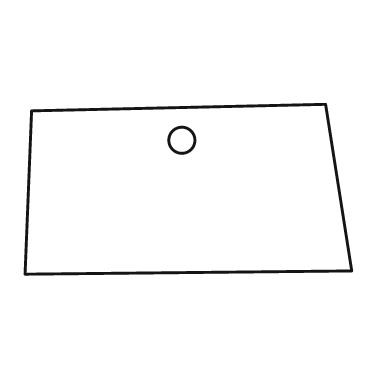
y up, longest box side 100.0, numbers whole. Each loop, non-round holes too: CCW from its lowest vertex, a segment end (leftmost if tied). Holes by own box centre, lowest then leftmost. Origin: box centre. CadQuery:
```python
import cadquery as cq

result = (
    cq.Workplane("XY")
    .moveTo(-50.0, -26.0)
    .lineTo(50.0, -25.0)
    .lineTo(42.0, 26.0)
    .lineTo(-48.0, 24.0)
    .close()
    .moveTo(-2.0, 15.0)
    .circle(4.0)
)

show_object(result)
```